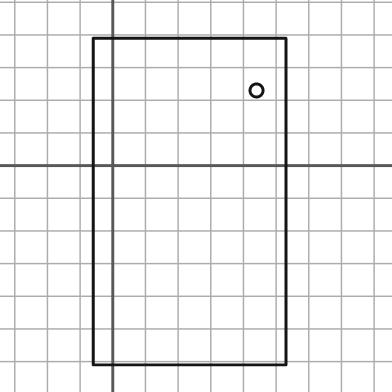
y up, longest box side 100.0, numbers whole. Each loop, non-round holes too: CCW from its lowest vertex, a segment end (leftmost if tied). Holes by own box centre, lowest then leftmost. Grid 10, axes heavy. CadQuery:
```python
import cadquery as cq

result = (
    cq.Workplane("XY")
    .moveTo(-6.0, -61.0)
    .lineTo(53.0, -61.0)
    .lineTo(53.0, 39.0)
    .lineTo(-6.0, 39.0)
    .close()
    .moveTo(44.0, 23.0)
    .circle(2.0)
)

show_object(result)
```